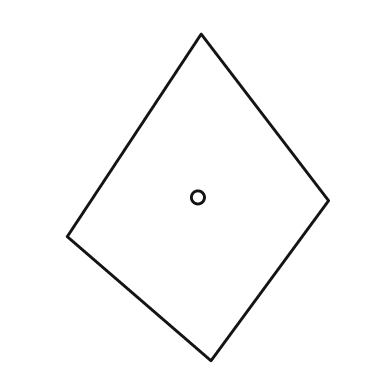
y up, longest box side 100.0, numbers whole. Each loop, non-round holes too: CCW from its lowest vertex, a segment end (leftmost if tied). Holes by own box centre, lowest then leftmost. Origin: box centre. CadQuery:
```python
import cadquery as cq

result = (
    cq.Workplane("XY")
    .moveTo(4.0, -50.0)
    .lineTo(40.0, -1.0)
    .lineTo(1.0, 50.0)
    .lineTo(-40.0, -12.0)
    .close()
    .moveTo(0.0, 0.0)
    .circle(2.0)
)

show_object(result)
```